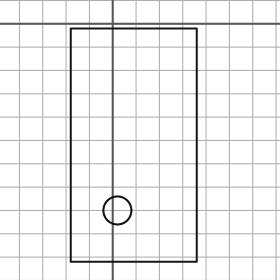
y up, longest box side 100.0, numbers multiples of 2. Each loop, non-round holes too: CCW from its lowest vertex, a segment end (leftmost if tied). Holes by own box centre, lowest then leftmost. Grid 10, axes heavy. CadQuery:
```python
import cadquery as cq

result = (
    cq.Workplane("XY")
    .moveTo(-18.0, -102.0)
    .lineTo(36.0, -102.0)
    .lineTo(36.0, -2.0)
    .lineTo(-18.0, -2.0)
    .close()
    .moveTo(2.0, -80.0)
    .circle(6.0)
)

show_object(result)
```